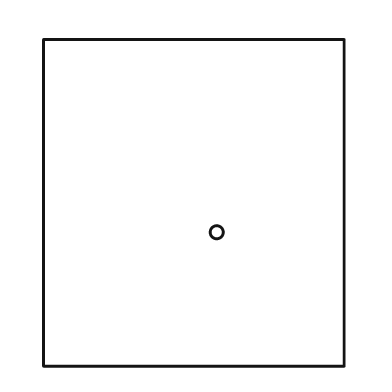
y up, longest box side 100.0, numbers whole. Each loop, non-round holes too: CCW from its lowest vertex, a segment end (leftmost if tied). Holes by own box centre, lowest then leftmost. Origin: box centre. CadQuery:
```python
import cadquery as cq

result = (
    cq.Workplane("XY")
    .moveTo(-46.0, -50.0)
    .lineTo(46.0, -50.0)
    .lineTo(46.0, 50.0)
    .lineTo(-46.0, 50.0)
    .close()
    .moveTo(7.0, -9.0)
    .circle(2.0)
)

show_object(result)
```